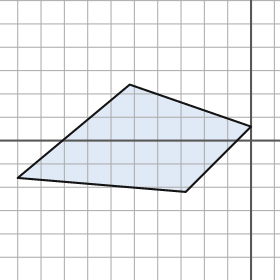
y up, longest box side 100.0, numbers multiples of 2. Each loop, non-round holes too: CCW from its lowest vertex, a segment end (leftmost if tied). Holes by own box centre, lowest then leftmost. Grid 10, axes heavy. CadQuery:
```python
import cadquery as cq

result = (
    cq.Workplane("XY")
    .moveTo(-28.0, -22.0)
    .lineTo(0.0, 6.0)
    .lineTo(-52.0, 24.0)
    .lineTo(-100.0, -16.0)
    .close()
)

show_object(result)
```